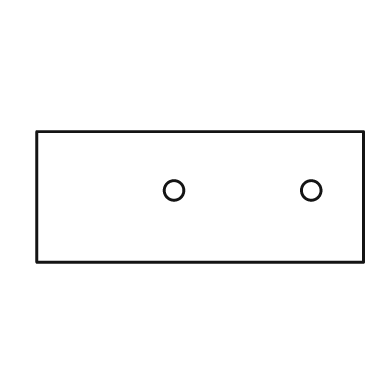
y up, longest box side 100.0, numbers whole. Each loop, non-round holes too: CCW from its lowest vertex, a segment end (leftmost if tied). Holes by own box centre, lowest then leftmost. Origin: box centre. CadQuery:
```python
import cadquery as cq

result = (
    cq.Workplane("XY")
    .moveTo(-50.0, -20.0)
    .lineTo(50.0, -20.0)
    .lineTo(50.0, 20.0)
    .lineTo(-50.0, 20.0)
    .close()
    .moveTo(-8.0, 2.0)
    .circle(3.0)
    .moveTo(34.0, 2.0)
    .circle(3.0)
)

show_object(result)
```